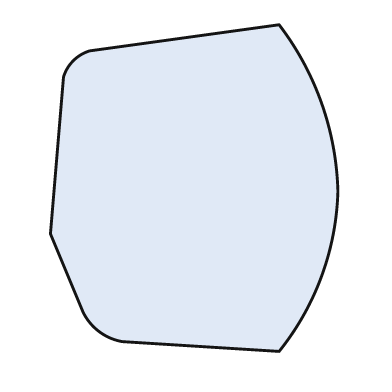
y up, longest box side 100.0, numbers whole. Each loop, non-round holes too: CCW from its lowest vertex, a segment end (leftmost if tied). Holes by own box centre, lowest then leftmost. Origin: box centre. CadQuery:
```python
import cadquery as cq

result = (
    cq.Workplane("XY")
    .moveTo(26.0, -50.0)
    .threePointArc((39.0, -27.0), (44.0, -1.0))
    .threePointArc((39.0, 26.0), (26.0, 50.0))
    .lineTo(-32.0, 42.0)
    .threePointArc((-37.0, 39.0), (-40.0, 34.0))
    .lineTo(-44.0, -14.0)
    .lineTo(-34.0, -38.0)
    .threePointArc((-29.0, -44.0), (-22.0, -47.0))
    .close()
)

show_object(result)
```